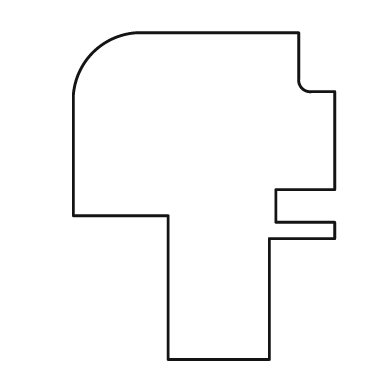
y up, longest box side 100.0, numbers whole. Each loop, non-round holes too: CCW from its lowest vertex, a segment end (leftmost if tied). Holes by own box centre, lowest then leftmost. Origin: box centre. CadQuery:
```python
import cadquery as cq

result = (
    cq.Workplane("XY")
    .moveTo(-11.0, -50.0)
    .lineTo(20.0, -50.0)
    .lineTo(20.0, -13.0)
    .lineTo(40.0, -13.0)
    .lineTo(40.0, -8.0)
    .lineTo(22.0, -8.0)
    .lineTo(22.0, 2.0)
    .lineTo(40.0, 2.0)
    .lineTo(40.0, 32.0)
    .lineTo(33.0, 32.0)
    .threePointArc((30.0, 33.0), (29.0, 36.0))
    .lineTo(29.0, 50.0)
    .lineTo(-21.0, 50.0)
    .threePointArc((-34.0, 44.0), (-40.0, 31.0))
    .lineTo(-40.0, -6.0)
    .lineTo(-11.0, -6.0)
    .close()
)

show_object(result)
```